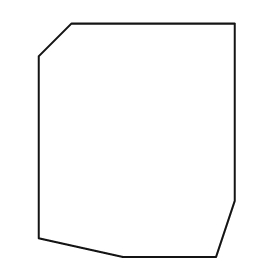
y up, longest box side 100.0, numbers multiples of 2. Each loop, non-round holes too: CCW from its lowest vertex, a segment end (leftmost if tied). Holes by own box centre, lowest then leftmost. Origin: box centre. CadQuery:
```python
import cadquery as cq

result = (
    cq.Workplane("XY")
    .moveTo(-6.0, -50.0)
    .lineTo(34.0, -50.0)
    .lineTo(42.0, -26.0)
    .lineTo(42.0, 50.0)
    .lineTo(-28.0, 50.0)
    .lineTo(-42.0, 36.0)
    .lineTo(-42.0, -42.0)
    .close()
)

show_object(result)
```